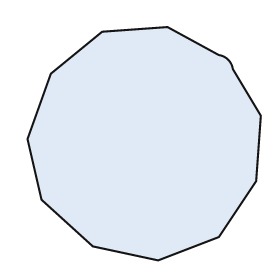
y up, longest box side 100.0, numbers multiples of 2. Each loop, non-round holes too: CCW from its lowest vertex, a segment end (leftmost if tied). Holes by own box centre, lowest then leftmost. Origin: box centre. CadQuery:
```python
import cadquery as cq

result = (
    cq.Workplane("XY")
    .moveTo(6.0, -50.0)
    .lineTo(32.0, -40.0)
    .lineTo(48.0, -16.0)
    .lineTo(50.0, 12.0)
    .lineTo(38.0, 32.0)
    .threePointArc((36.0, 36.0), (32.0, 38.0))
    .lineTo(10.0, 50.0)
    .lineTo(-18.0, 48.0)
    .lineTo(-40.0, 30.0)
    .lineTo(-50.0, 2.0)
    .lineTo(-44.0, -24.0)
    .lineTo(-22.0, -44.0)
    .close()
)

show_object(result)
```